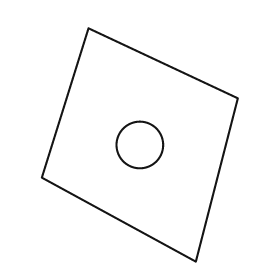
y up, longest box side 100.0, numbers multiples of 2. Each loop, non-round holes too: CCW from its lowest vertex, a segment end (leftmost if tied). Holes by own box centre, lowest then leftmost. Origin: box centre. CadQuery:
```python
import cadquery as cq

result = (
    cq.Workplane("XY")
    .moveTo(24.0, -50.0)
    .lineTo(42.0, 20.0)
    .lineTo(-22.0, 50.0)
    .lineTo(-42.0, -14.0)
    .close()
    .moveTo(0.0, 0.0)
    .circle(10.0)
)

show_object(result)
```